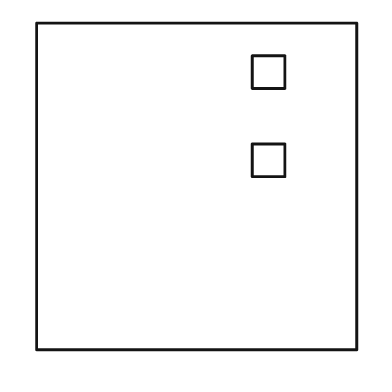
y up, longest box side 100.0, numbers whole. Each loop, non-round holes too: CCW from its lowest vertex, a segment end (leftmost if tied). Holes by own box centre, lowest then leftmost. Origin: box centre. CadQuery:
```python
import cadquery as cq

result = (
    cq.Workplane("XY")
    .moveTo(-49.0, -50.0)
    .lineTo(49.0, -50.0)
    .lineTo(49.0, 50.0)
    .lineTo(-49.0, 50.0)
    .close()
    .moveTo(17.0, 3.0)
    .lineTo(27.0, 3.0)
    .lineTo(27.0, 13.0)
    .lineTo(17.0, 13.0)
    .close()
    .moveTo(17.0, 30.0)
    .lineTo(27.0, 30.0)
    .lineTo(27.0, 40.0)
    .lineTo(17.0, 40.0)
    .close()
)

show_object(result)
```